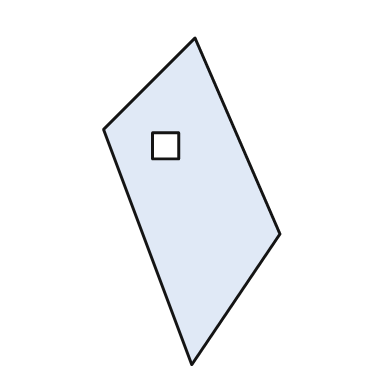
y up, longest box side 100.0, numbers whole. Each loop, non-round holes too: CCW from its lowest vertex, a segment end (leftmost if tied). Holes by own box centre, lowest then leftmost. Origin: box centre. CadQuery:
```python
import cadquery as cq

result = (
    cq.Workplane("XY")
    .moveTo(0.0, -50.0)
    .lineTo(27.0, -10.0)
    .lineTo(1.0, 50.0)
    .lineTo(-27.0, 22.0)
    .close()
    .moveTo(-12.0, 13.0)
    .lineTo(-4.0, 13.0)
    .lineTo(-4.0, 21.0)
    .lineTo(-12.0, 21.0)
    .close()
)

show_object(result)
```